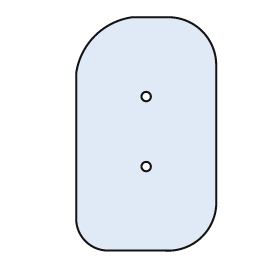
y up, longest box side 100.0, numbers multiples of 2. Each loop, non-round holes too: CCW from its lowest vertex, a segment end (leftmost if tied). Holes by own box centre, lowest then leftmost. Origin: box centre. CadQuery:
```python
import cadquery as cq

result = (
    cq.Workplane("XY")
    .moveTo(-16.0, -50.0)
    .lineTo(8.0, -50.0)
    .threePointArc((24.0, -44.0), (30.0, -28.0))
    .lineTo(30.0, 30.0)
    .threePointArc((24.0, 44.0), (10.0, 50.0))
    .lineTo(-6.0, 50.0)
    .threePointArc((-22.0, 42.0), (-30.0, 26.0))
    .lineTo(-30.0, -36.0)
    .threePointArc((-26.0, -46.0), (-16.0, -50.0))
    .close()
    .moveTo(0.0, -14.0)
    .circle(2.0)
    .moveTo(0.0, 16.0)
    .circle(2.0)
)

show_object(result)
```